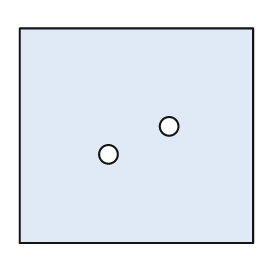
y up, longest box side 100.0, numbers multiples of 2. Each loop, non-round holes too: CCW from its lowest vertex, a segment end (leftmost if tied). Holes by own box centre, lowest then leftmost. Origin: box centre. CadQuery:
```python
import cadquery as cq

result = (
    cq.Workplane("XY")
    .moveTo(-50.0, -46.0)
    .lineTo(50.0, -46.0)
    .lineTo(50.0, 46.0)
    .lineTo(-50.0, 46.0)
    .close()
    .moveTo(-12.0, -8.0)
    .circle(4.0)
    .moveTo(14.0, 4.0)
    .circle(4.0)
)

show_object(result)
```